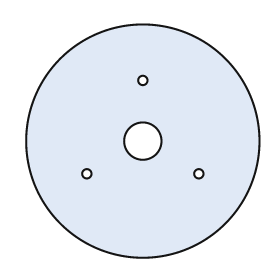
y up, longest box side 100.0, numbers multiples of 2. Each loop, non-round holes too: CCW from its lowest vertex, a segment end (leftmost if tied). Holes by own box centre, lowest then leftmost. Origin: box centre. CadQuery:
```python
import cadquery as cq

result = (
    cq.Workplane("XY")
    .moveTo(0.0, 0.0)
    .circle(50.0)
    .moveTo(-24.0, -14.0)
    .circle(2.0)
    .moveTo(24.0, -14.0)
    .circle(2.0)
    .moveTo(0.0, 0.0)
    .circle(8.0)
    .moveTo(0.0, 26.0)
    .circle(2.0)
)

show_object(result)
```